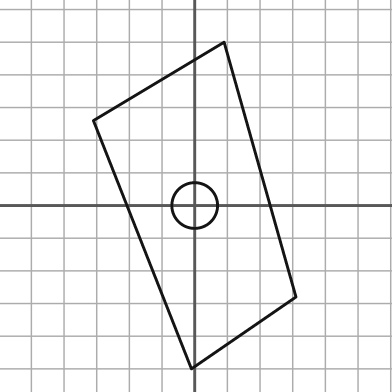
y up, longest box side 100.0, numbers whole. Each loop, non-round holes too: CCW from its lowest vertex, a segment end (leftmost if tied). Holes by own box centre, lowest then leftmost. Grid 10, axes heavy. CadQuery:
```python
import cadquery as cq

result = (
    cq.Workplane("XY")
    .moveTo(-1.0, -50.0)
    .lineTo(31.0, -28.0)
    .lineTo(9.0, 50.0)
    .lineTo(-31.0, 26.0)
    .close()
    .moveTo(0.0, 0.0)
    .circle(7.0)
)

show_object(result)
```